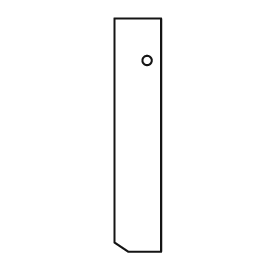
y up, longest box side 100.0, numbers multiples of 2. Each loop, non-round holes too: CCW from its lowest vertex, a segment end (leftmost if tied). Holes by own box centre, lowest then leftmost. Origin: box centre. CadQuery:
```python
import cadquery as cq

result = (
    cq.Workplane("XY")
    .moveTo(-4.0, -50.0)
    .lineTo(10.0, -50.0)
    .lineTo(10.0, 50.0)
    .lineTo(-10.0, 50.0)
    .lineTo(-10.0, -46.0)
    .close()
    .moveTo(4.0, 32.0)
    .circle(2.0)
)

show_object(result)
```